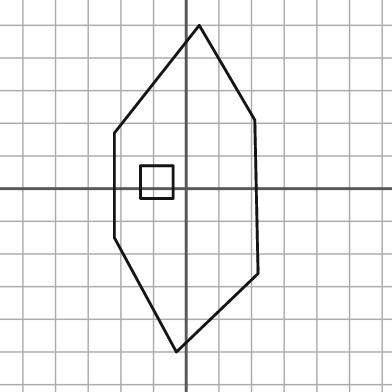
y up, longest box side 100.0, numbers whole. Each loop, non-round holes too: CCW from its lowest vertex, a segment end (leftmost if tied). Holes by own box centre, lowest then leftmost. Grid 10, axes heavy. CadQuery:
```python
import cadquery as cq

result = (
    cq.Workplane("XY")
    .moveTo(-3.0, -50.0)
    .lineTo(22.0, -26.0)
    .lineTo(21.0, 21.0)
    .lineTo(4.0, 50.0)
    .lineTo(-22.0, 17.0)
    .lineTo(-22.0, -15.0)
    .close()
    .moveTo(-14.0, -3.0)
    .lineTo(-4.0, -3.0)
    .lineTo(-4.0, 7.0)
    .lineTo(-14.0, 7.0)
    .close()
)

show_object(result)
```